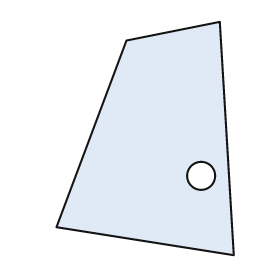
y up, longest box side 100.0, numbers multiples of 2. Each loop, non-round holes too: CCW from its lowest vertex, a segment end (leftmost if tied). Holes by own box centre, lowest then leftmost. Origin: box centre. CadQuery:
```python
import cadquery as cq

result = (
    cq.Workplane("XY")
    .moveTo(38.0, -50.0)
    .lineTo(32.0, 50.0)
    .lineTo(-8.0, 42.0)
    .lineTo(-38.0, -38.0)
    .close()
    .moveTo(24.0, -16.0)
    .circle(6.0)
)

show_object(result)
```